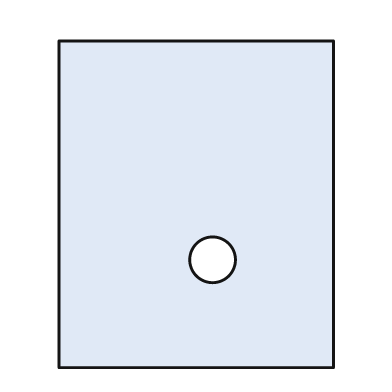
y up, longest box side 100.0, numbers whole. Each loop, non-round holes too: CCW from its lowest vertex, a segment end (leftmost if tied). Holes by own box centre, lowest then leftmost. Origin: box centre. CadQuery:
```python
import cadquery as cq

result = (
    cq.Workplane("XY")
    .moveTo(-42.0, -50.0)
    .lineTo(42.0, -50.0)
    .lineTo(42.0, 50.0)
    .lineTo(-42.0, 50.0)
    .close()
    .moveTo(5.0, -17.0)
    .circle(7.0)
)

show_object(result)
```